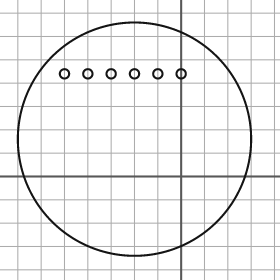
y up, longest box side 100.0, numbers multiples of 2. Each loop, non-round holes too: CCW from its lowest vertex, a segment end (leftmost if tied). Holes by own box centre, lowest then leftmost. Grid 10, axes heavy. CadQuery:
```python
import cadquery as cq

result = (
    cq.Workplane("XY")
    .moveTo(-20.0, 16.0)
    .circle(50.0)
    .moveTo(-50.0, 44.0)
    .circle(2.0)
    .moveTo(-40.0, 44.0)
    .circle(2.0)
    .moveTo(-30.0, 44.0)
    .circle(2.0)
    .moveTo(-20.0, 44.0)
    .circle(2.0)
    .moveTo(-10.0, 44.0)
    .circle(2.0)
    .moveTo(0.0, 44.0)
    .circle(2.0)
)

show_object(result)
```